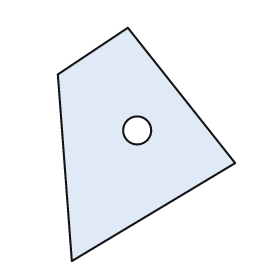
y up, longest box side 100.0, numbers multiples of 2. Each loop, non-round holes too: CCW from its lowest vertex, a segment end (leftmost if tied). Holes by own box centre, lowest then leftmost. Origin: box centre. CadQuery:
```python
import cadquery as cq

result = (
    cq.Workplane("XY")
    .moveTo(-32.0, -50.0)
    .lineTo(38.0, -8.0)
    .lineTo(-8.0, 50.0)
    .lineTo(-38.0, 30.0)
    .close()
    .moveTo(-4.0, 6.0)
    .circle(6.0)
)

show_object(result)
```